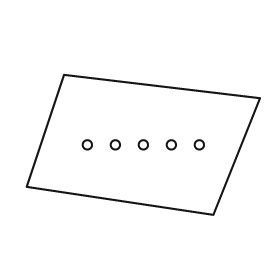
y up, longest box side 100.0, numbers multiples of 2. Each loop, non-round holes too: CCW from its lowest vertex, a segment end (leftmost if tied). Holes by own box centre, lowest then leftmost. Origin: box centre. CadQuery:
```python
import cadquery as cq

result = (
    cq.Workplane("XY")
    .moveTo(30.0, -30.0)
    .lineTo(50.0, 20.0)
    .lineTo(-34.0, 30.0)
    .lineTo(-50.0, -18.0)
    .close()
    .moveTo(-24.0, 0.0)
    .circle(2.0)
    .moveTo(-12.0, 0.0)
    .circle(2.0)
    .moveTo(0.0, 0.0)
    .circle(2.0)
    .moveTo(12.0, 0.0)
    .circle(2.0)
    .moveTo(24.0, 0.0)
    .circle(2.0)
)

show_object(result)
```